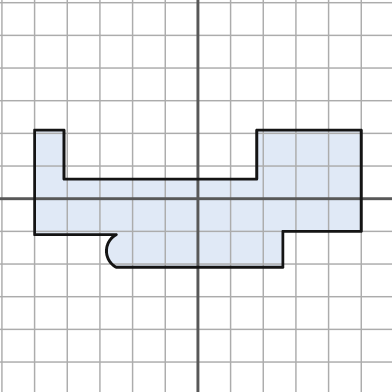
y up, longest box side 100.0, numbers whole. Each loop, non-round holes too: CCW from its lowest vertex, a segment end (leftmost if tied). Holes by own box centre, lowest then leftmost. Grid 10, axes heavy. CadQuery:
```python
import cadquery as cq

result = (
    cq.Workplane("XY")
    .moveTo(-25.0, -21.0)
    .lineTo(26.0, -21.0)
    .lineTo(26.0, -10.0)
    .lineTo(50.0, -10.0)
    .lineTo(50.0, 21.0)
    .lineTo(18.0, 21.0)
    .lineTo(18.0, 6.0)
    .lineTo(-41.0, 6.0)
    .lineTo(-41.0, 21.0)
    .lineTo(-50.0, 21.0)
    .lineTo(-50.0, -11.0)
    .lineTo(-25.0, -11.0)
    .threePointArc((-28.0, -16.0), (-25.0, -21.0))
    .close()
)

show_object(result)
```